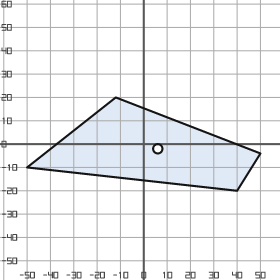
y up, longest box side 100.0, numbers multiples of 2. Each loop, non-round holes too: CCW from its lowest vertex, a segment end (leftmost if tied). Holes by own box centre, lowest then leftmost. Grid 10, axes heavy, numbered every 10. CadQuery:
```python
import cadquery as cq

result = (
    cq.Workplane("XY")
    .moveTo(40.0, -20.0)
    .lineTo(50.0, -4.0)
    .lineTo(-12.0, 20.0)
    .lineTo(-50.0, -10.0)
    .close()
    .moveTo(6.0, -2.0)
    .circle(2.0)
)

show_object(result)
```